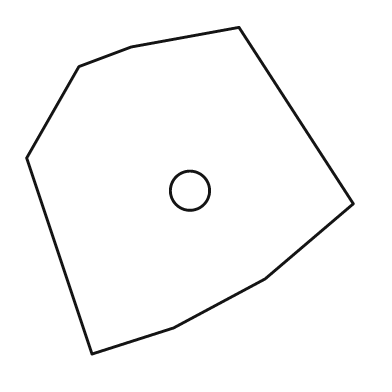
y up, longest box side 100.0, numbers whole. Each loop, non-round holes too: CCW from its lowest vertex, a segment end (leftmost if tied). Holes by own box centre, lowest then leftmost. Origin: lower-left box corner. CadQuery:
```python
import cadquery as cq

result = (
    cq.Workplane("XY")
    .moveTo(20.0, 0.0)
    .lineTo(45.0, 8.0)
    .lineTo(73.0, 23.0)
    .lineTo(100.0, 46.0)
    .lineTo(65.0, 100.0)
    .lineTo(32.0, 94.0)
    .lineTo(16.0, 88.0)
    .lineTo(0.0, 60.0)
    .close()
    .moveTo(50.0, 50.0)
    .circle(6.0)
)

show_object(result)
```